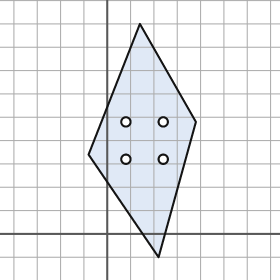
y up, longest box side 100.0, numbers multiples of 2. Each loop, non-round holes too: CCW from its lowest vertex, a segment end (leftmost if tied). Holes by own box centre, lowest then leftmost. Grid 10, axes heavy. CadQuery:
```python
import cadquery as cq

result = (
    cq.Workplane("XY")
    .moveTo(22.0, -10.0)
    .lineTo(38.0, 48.0)
    .lineTo(14.0, 90.0)
    .lineTo(-8.0, 34.0)
    .close()
    .moveTo(8.0, 32.0)
    .circle(2.0)
    .moveTo(24.0, 32.0)
    .circle(2.0)
    .moveTo(8.0, 48.0)
    .circle(2.0)
    .moveTo(24.0, 48.0)
    .circle(2.0)
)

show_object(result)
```